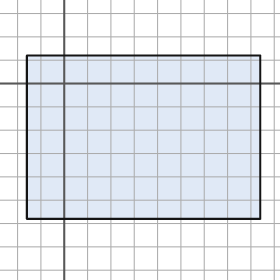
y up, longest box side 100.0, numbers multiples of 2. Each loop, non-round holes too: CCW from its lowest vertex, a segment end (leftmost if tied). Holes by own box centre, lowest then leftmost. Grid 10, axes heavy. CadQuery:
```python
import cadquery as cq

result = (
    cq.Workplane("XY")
    .moveTo(-16.0, -58.0)
    .lineTo(84.0, -58.0)
    .lineTo(84.0, 12.0)
    .lineTo(-16.0, 12.0)
    .close()
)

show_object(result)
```